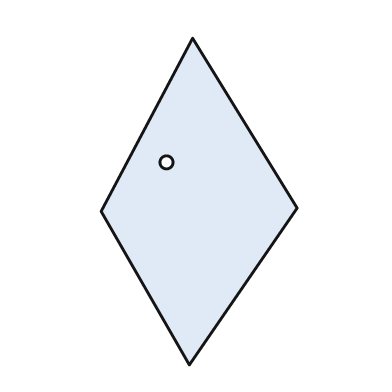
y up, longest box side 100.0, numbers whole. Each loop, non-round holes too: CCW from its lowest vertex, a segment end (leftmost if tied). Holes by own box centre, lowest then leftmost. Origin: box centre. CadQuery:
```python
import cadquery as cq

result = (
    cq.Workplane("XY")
    .moveTo(-3.0, -50.0)
    .lineTo(30.0, -2.0)
    .lineTo(-2.0, 50.0)
    .lineTo(-30.0, -3.0)
    .close()
    .moveTo(-10.0, 12.0)
    .circle(2.0)
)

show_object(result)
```